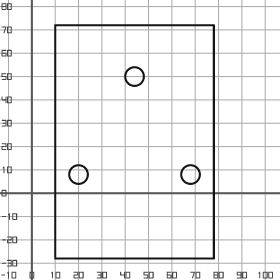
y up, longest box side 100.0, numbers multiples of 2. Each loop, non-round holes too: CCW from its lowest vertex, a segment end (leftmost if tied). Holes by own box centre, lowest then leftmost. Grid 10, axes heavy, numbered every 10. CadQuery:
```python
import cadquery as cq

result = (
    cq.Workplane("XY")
    .moveTo(10.0, -28.0)
    .lineTo(78.0, -28.0)
    .lineTo(78.0, 72.0)
    .lineTo(10.0, 72.0)
    .close()
    .moveTo(20.0, 8.0)
    .circle(4.0)
    .moveTo(68.0, 8.0)
    .circle(4.0)
    .moveTo(44.0, 50.0)
    .circle(4.0)
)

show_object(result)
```